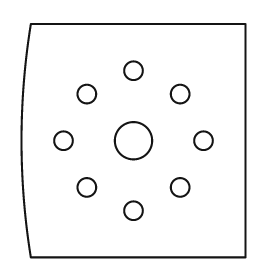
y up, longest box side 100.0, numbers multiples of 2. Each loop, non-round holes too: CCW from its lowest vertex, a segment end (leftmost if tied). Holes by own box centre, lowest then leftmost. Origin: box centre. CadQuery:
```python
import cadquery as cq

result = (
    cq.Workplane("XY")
    .moveTo(-44.0, -50.0)
    .lineTo(48.0, -50.0)
    .lineTo(48.0, 50.0)
    .lineTo(-44.0, 50.0)
    .threePointArc((-48.0, 0.0), (-44.0, -50.0))
    .close()
    .moveTo(0.0, -30.0)
    .circle(4.0)
    .moveTo(-20.0, -20.0)
    .circle(4.0)
    .moveTo(20.0, -20.0)
    .circle(4.0)
    .moveTo(-30.0, 0.0)
    .circle(4.0)
    .moveTo(0.0, 0.0)
    .circle(8.0)
    .moveTo(30.0, 0.0)
    .circle(4.0)
    .moveTo(-20.0, 20.0)
    .circle(4.0)
    .moveTo(20.0, 20.0)
    .circle(4.0)
    .moveTo(0.0, 30.0)
    .circle(4.0)
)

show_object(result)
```